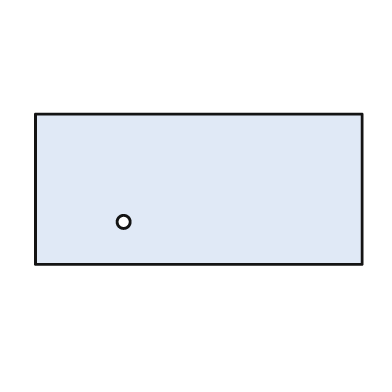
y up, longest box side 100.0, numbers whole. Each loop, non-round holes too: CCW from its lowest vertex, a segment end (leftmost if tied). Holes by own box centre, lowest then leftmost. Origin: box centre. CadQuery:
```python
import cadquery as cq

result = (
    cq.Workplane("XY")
    .moveTo(-50.0, -23.0)
    .lineTo(50.0, -23.0)
    .lineTo(50.0, 23.0)
    .lineTo(-50.0, 23.0)
    .close()
    .moveTo(-23.0, -10.0)
    .circle(2.0)
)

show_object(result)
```